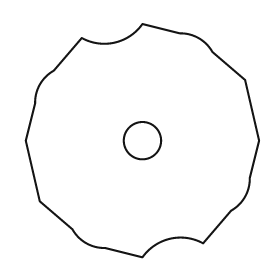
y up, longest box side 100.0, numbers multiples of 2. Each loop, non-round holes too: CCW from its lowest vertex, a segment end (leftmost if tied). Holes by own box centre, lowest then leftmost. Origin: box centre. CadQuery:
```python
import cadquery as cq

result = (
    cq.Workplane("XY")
    .moveTo(0.0, -50.0)
    .threePointArc((12.0, -42.0), (26.0, -44.0))
    .lineTo(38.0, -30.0)
    .threePointArc((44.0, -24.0), (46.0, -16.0))
    .lineTo(50.0, 0.0)
    .lineTo(44.0, 26.0)
    .lineTo(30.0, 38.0)
    .threePointArc((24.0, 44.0), (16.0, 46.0))
    .lineTo(0.0, 50.0)
    .threePointArc((-12.0, 42.0), (-26.0, 44.0))
    .lineTo(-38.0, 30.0)
    .threePointArc((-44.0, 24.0), (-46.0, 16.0))
    .lineTo(-50.0, 0.0)
    .lineTo(-44.0, -26.0)
    .lineTo(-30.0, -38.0)
    .threePointArc((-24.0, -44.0), (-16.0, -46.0))
    .close()
    .moveTo(0.0, 0.0)
    .circle(8.0)
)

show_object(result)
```